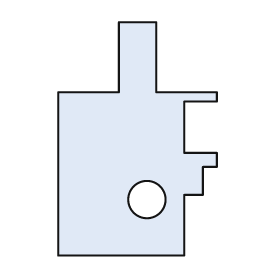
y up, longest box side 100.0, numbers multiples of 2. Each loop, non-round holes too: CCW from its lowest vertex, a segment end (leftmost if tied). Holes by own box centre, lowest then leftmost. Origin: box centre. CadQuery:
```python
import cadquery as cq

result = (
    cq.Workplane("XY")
    .moveTo(-34.0, -50.0)
    .lineTo(20.0, -50.0)
    .lineTo(20.0, -24.0)
    .lineTo(28.0, -24.0)
    .lineTo(28.0, -12.0)
    .lineTo(34.0, -12.0)
    .lineTo(34.0, -6.0)
    .lineTo(20.0, -6.0)
    .lineTo(20.0, 16.0)
    .lineTo(34.0, 16.0)
    .lineTo(34.0, 20.0)
    .lineTo(8.0, 20.0)
    .lineTo(8.0, 50.0)
    .lineTo(-8.0, 50.0)
    .lineTo(-8.0, 20.0)
    .lineTo(-34.0, 20.0)
    .close()
    .moveTo(4.0, -26.0)
    .circle(8.0)
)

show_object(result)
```